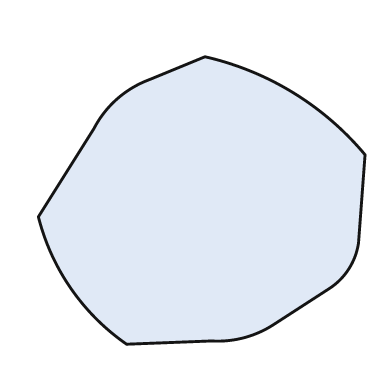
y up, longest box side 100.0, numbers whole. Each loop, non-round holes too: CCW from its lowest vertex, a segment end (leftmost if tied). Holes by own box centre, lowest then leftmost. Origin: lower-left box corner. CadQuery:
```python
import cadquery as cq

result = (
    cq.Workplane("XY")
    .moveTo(27.0, 0.0)
    .lineTo(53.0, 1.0)
    .threePointArc((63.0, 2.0), (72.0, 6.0))
    .lineTo(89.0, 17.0)
    .threePointArc((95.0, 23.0), (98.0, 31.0))
    .lineTo(100.0, 58.0)
    .threePointArc((78.0, 77.0), (51.0, 88.0))
    .lineTo(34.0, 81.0)
    .threePointArc((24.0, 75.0), (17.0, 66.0))
    .lineTo(0.0, 39.0)
    .threePointArc((10.0, 17.0), (27.0, 0.0))
    .close()
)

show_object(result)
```